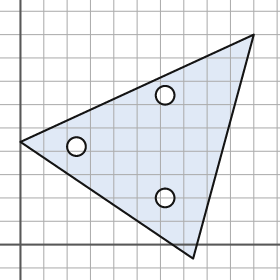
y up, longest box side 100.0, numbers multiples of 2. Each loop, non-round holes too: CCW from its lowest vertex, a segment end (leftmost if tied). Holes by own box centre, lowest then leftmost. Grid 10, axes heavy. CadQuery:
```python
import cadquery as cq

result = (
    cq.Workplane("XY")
    .moveTo(74.0, -6.0)
    .lineTo(100.0, 90.0)
    .lineTo(0.0, 44.0)
    .close()
    .moveTo(62.0, 20.0)
    .circle(4.0)
    .moveTo(24.0, 42.0)
    .circle(4.0)
    .moveTo(62.0, 64.0)
    .circle(4.0)
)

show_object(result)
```